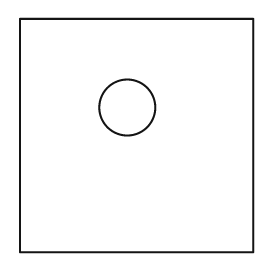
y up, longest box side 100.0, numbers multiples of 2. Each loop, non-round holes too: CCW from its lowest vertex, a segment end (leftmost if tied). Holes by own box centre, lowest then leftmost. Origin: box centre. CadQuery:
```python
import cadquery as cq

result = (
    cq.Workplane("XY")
    .moveTo(-50.0, -50.0)
    .lineTo(50.0, -50.0)
    .lineTo(50.0, 50.0)
    .lineTo(-50.0, 50.0)
    .close()
    .moveTo(-4.0, 12.0)
    .circle(12.0)
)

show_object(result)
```